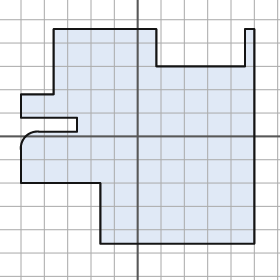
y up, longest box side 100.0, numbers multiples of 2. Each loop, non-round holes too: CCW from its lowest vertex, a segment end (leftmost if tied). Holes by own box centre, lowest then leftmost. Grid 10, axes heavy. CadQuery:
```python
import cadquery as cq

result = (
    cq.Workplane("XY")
    .moveTo(-16.0, -46.0)
    .lineTo(50.0, -46.0)
    .lineTo(50.0, 46.0)
    .lineTo(46.0, 46.0)
    .lineTo(46.0, 30.0)
    .lineTo(8.0, 30.0)
    .lineTo(8.0, 46.0)
    .lineTo(-36.0, 46.0)
    .lineTo(-36.0, 18.0)
    .lineTo(-50.0, 18.0)
    .lineTo(-50.0, 8.0)
    .lineTo(-26.0, 8.0)
    .lineTo(-26.0, 2.0)
    .lineTo(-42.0, 2.0)
    .threePointArc((-48.0, 0.0), (-50.0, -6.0))
    .lineTo(-50.0, -20.0)
    .lineTo(-16.0, -20.0)
    .close()
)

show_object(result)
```